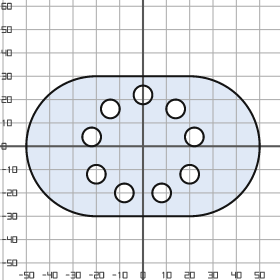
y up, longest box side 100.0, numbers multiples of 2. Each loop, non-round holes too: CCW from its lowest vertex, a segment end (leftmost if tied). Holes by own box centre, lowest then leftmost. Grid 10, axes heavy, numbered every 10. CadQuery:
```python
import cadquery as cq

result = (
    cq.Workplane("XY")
    .moveTo(-20.0, -30.0)
    .lineTo(20.0, -30.0)
    .threePointArc((50.0, 0.0), (20.0, 30.0))
    .lineTo(-20.0, 30.0)
    .threePointArc((-50.0, 0.0), (-20.0, -30.0))
    .close()
    .moveTo(-8.0, -20.0)
    .circle(4.0)
    .moveTo(8.0, -20.0)
    .circle(4.0)
    .moveTo(-20.0, -12.0)
    .circle(4.0)
    .moveTo(20.0, -12.0)
    .circle(4.0)
    .moveTo(-22.0, 4.0)
    .circle(4.0)
    .moveTo(22.0, 4.0)
    .circle(4.0)
    .moveTo(-14.0, 16.0)
    .circle(4.0)
    .moveTo(14.0, 16.0)
    .circle(4.0)
    .moveTo(0.0, 22.0)
    .circle(4.0)
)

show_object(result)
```